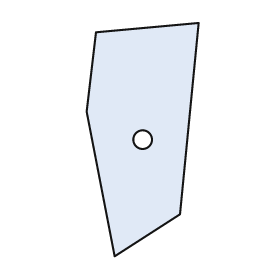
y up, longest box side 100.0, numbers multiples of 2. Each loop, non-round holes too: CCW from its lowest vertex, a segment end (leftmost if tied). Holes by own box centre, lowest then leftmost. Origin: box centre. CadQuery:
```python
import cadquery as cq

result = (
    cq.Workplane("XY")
    .moveTo(-12.0, -50.0)
    .lineTo(16.0, -32.0)
    .lineTo(24.0, 50.0)
    .lineTo(-20.0, 46.0)
    .lineTo(-24.0, 12.0)
    .close()
    .moveTo(0.0, 0.0)
    .circle(4.0)
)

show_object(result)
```